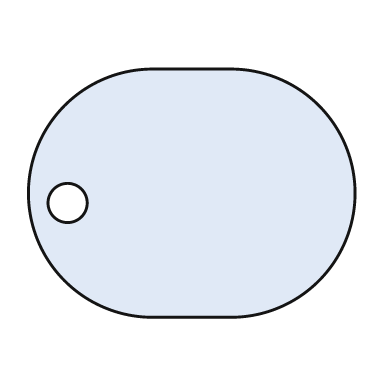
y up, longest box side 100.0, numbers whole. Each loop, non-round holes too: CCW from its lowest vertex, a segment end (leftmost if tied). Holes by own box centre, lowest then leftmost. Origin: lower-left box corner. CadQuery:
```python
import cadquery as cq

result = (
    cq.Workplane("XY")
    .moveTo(38.0, 0.0)
    .lineTo(62.0, 0.0)
    .threePointArc((100.0, 38.0), (62.0, 76.0))
    .lineTo(38.0, 76.0)
    .threePointArc((0.0, 38.0), (38.0, 0.0))
    .close()
    .moveTo(12.0, 35.0)
    .circle(6.0)
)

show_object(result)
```